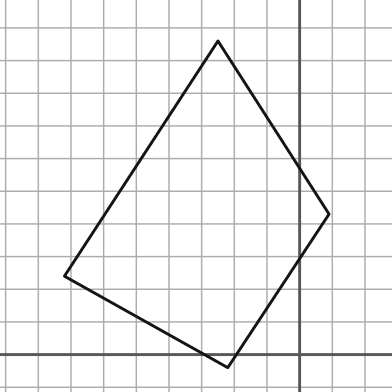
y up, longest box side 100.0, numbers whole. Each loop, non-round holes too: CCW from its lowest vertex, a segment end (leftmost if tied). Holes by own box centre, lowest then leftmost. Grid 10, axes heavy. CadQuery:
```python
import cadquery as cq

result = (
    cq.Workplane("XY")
    .moveTo(-22.0, -4.0)
    .lineTo(9.0, 43.0)
    .lineTo(-25.0, 96.0)
    .lineTo(-72.0, 24.0)
    .close()
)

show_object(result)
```